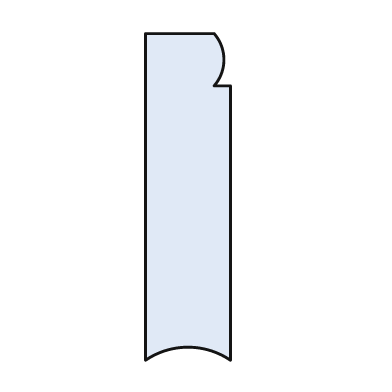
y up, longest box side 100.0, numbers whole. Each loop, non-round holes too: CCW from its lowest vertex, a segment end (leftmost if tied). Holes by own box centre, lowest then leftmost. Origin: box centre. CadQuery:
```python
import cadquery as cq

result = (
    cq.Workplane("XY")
    .moveTo(-13.0, -50.0)
    .threePointArc((0.0, -46.0), (13.0, -50.0))
    .lineTo(13.0, 34.0)
    .lineTo(8.0, 34.0)
    .threePointArc((11.0, 42.0), (8.0, 50.0))
    .lineTo(-13.0, 50.0)
    .close()
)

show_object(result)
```